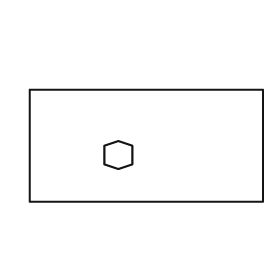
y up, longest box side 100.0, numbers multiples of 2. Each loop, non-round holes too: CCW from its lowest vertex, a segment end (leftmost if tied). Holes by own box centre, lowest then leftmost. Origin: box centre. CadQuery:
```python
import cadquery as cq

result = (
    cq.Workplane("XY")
    .moveTo(-50.0, -24.0)
    .lineTo(50.0, -24.0)
    .lineTo(50.0, 24.0)
    .lineTo(-50.0, 24.0)
    .close()
    .moveTo(-12.0, -10.0)
    .lineTo(-6.0, -8.0)
    .lineTo(-6.0, 0.0)
    .lineTo(-12.0, 2.0)
    .lineTo(-18.0, 0.0)
    .lineTo(-18.0, -8.0)
    .close()
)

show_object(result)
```